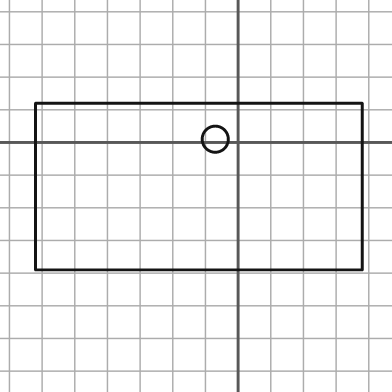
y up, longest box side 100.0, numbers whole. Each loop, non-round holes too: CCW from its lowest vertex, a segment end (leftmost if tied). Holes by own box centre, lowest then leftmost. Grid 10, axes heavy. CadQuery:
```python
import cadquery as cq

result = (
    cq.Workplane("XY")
    .moveTo(-62.0, -39.0)
    .lineTo(38.0, -39.0)
    .lineTo(38.0, 12.0)
    .lineTo(-62.0, 12.0)
    .close()
    .moveTo(-7.0, 1.0)
    .circle(4.0)
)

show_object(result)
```